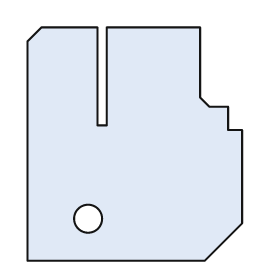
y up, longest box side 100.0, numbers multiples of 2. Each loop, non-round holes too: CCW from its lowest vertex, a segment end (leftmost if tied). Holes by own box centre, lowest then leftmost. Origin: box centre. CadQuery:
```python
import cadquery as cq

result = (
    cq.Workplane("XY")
    .moveTo(-46.0, -50.0)
    .lineTo(30.0, -50.0)
    .lineTo(46.0, -34.0)
    .lineTo(46.0, 6.0)
    .lineTo(40.0, 6.0)
    .lineTo(40.0, 16.0)
    .lineTo(32.0, 16.0)
    .lineTo(28.0, 20.0)
    .lineTo(28.0, 50.0)
    .lineTo(-12.0, 50.0)
    .lineTo(-12.0, 8.0)
    .lineTo(-16.0, 8.0)
    .lineTo(-16.0, 50.0)
    .lineTo(-40.0, 50.0)
    .lineTo(-46.0, 44.0)
    .close()
    .moveTo(-20.0, -32.0)
    .circle(6.0)
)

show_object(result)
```